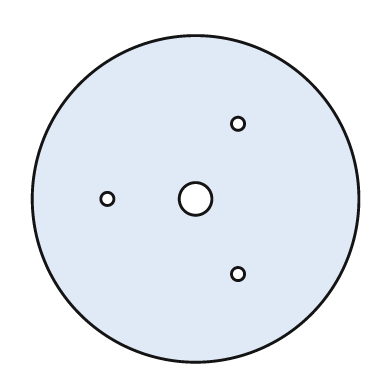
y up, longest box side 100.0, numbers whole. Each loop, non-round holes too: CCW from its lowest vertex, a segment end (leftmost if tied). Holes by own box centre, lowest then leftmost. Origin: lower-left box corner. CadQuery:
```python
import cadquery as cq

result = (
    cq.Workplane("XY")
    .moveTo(50.0, 50.0)
    .circle(50.0)
    .moveTo(63.0, 27.0)
    .circle(2.0)
    .moveTo(23.0, 50.0)
    .circle(2.0)
    .moveTo(50.0, 50.0)
    .circle(5.0)
    .moveTo(63.0, 73.0)
    .circle(2.0)
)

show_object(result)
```